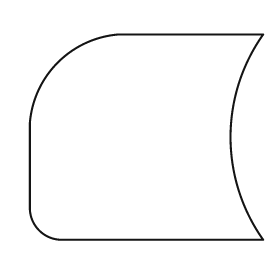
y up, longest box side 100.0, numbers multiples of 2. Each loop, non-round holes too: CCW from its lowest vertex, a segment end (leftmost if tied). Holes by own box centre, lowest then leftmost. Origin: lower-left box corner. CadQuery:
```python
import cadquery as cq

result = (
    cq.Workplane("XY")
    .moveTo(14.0, 0.0)
    .lineTo(100.0, 0.0)
    .threePointArc((86.0, 44.0), (100.0, 88.0))
    .lineTo(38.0, 88.0)
    .threePointArc((12.0, 76.0), (0.0, 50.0))
    .lineTo(0.0, 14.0)
    .threePointArc((4.0, 4.0), (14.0, 0.0))
    .close()
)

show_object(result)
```